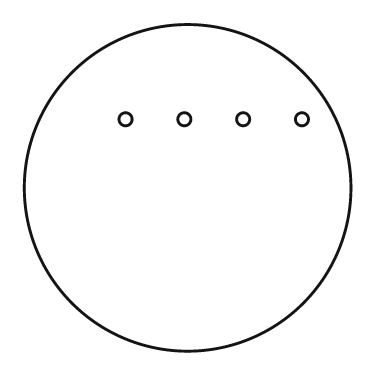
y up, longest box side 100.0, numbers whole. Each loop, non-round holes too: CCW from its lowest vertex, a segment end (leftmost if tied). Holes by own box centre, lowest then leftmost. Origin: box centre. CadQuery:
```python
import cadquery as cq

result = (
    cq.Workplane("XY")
    .moveTo(0.0, 0.0)
    .circle(50.0)
    .moveTo(-19.0, 21.0)
    .circle(2.0)
    .moveTo(-1.0, 21.0)
    .circle(2.0)
    .moveTo(17.0, 21.0)
    .circle(2.0)
    .moveTo(35.0, 21.0)
    .circle(2.0)
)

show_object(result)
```